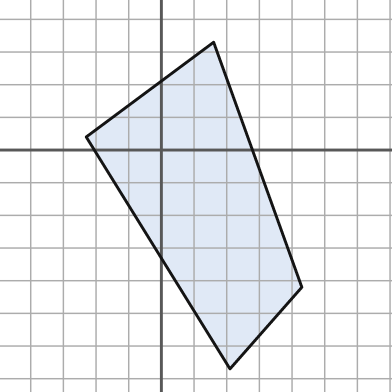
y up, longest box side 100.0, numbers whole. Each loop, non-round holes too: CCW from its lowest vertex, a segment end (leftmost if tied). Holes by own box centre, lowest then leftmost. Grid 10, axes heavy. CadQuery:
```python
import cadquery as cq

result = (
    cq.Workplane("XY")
    .moveTo(21.0, -67.0)
    .lineTo(43.0, -42.0)
    .lineTo(16.0, 33.0)
    .lineTo(-23.0, 4.0)
    .close()
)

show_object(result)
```